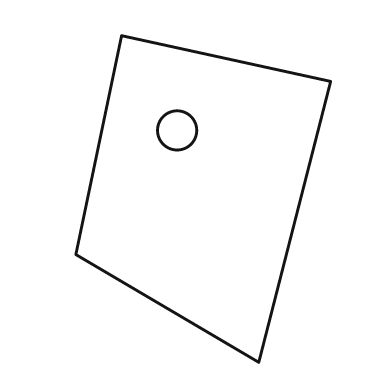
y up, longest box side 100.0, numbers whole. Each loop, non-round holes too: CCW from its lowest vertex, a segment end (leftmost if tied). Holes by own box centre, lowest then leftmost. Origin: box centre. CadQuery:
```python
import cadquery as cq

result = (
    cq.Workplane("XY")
    .moveTo(17.0, -50.0)
    .lineTo(39.0, 36.0)
    .lineTo(-25.0, 50.0)
    .lineTo(-39.0, -17.0)
    .close()
    .moveTo(-8.0, 21.0)
    .circle(6.0)
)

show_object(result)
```